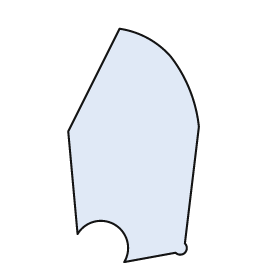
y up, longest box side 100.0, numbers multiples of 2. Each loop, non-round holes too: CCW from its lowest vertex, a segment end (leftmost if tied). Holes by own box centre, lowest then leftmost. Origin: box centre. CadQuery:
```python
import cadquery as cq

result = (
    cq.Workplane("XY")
    .moveTo(-4.0, -50.0)
    .lineTo(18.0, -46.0)
    .threePointArc((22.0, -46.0), (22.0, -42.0))
    .lineTo(28.0, 8.0)
    .threePointArc((24.0, 24.0), (16.0, 38.0))
    .threePointArc((6.0, 46.0), (-6.0, 50.0))
    .lineTo(-28.0, 6.0)
    .lineTo(-24.0, -38.0)
    .threePointArc((-8.0, -34.0), (-4.0, -50.0))
    .close()
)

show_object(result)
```